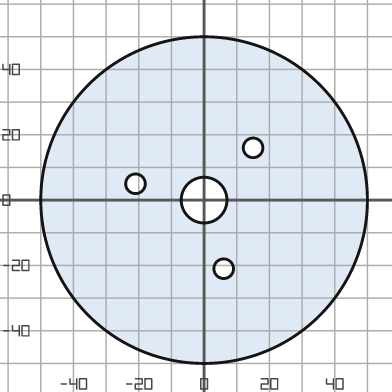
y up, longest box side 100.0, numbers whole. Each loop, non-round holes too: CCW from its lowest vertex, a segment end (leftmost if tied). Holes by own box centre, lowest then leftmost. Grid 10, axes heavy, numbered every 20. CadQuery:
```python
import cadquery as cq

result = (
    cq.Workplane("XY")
    .moveTo(0.0, 0.0)
    .circle(50.0)
    .moveTo(6.0, -21.0)
    .circle(3.0)
    .moveTo(0.0, 0.0)
    .circle(7.0)
    .moveTo(-21.0, 5.0)
    .circle(3.0)
    .moveTo(15.0, 16.0)
    .circle(3.0)
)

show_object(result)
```